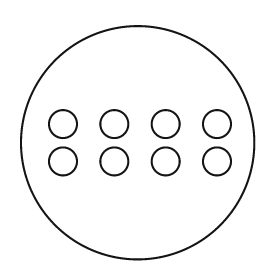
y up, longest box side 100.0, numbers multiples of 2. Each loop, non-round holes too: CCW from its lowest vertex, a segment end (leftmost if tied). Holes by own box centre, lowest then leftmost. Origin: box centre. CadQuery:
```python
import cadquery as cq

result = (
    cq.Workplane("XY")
    .moveTo(0.0, 0.0)
    .circle(50.0)
    .moveTo(-32.0, -8.0)
    .circle(6.0)
    .moveTo(-10.0, -8.0)
    .circle(6.0)
    .moveTo(12.0, -8.0)
    .circle(6.0)
    .moveTo(34.0, -8.0)
    .circle(6.0)
    .moveTo(-32.0, 8.0)
    .circle(6.0)
    .moveTo(-10.0, 8.0)
    .circle(6.0)
    .moveTo(12.0, 8.0)
    .circle(6.0)
    .moveTo(34.0, 8.0)
    .circle(6.0)
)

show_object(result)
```